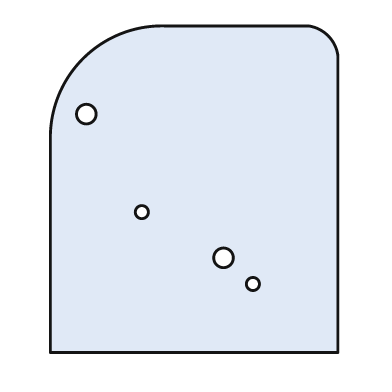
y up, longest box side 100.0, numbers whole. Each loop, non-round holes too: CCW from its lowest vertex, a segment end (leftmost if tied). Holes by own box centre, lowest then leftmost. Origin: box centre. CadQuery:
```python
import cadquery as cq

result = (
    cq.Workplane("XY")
    .moveTo(-44.0, -50.0)
    .lineTo(44.0, -50.0)
    .lineTo(44.0, 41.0)
    .threePointArc((41.0, 47.0), (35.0, 50.0))
    .lineTo(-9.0, 50.0)
    .threePointArc((-34.0, 40.0), (-44.0, 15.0))
    .close()
    .moveTo(18.0, -29.0)
    .circle(2.0)
    .moveTo(9.0, -21.0)
    .circle(3.0)
    .moveTo(-16.0, -7.0)
    .circle(2.0)
    .moveTo(-33.0, 23.0)
    .circle(3.0)
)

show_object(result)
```